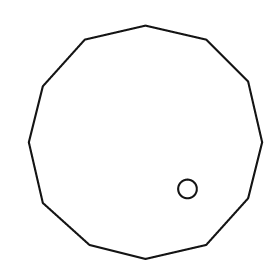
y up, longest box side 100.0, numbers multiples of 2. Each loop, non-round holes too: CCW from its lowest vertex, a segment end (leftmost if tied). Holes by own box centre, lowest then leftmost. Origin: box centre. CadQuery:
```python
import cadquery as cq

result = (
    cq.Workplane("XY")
    .moveTo(0.0, -50.0)
    .lineTo(26.0, -44.0)
    .lineTo(44.0, -24.0)
    .lineTo(50.0, 0.0)
    .lineTo(44.0, 26.0)
    .lineTo(26.0, 44.0)
    .lineTo(0.0, 50.0)
    .lineTo(-26.0, 44.0)
    .lineTo(-44.0, 24.0)
    .lineTo(-50.0, 0.0)
    .lineTo(-44.0, -26.0)
    .lineTo(-24.0, -44.0)
    .close()
    .moveTo(18.0, -20.0)
    .circle(4.0)
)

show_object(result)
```